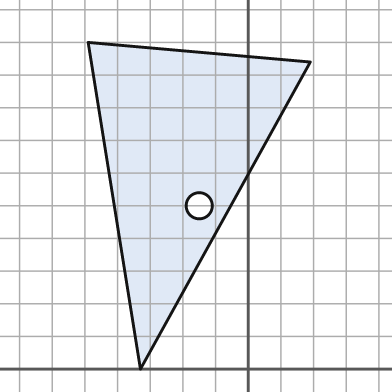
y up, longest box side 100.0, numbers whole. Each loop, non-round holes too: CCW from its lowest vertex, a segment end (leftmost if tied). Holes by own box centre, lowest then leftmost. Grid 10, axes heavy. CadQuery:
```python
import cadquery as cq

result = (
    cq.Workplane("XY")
    .moveTo(-33.0, 0.0)
    .lineTo(19.0, 94.0)
    .lineTo(-49.0, 100.0)
    .close()
    .moveTo(-15.0, 50.0)
    .circle(4.0)
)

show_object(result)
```